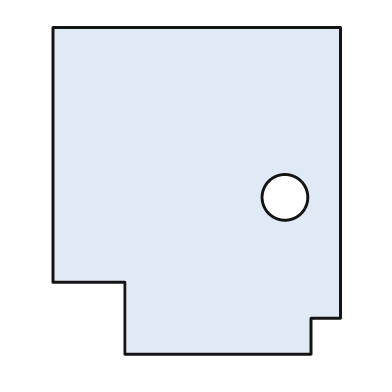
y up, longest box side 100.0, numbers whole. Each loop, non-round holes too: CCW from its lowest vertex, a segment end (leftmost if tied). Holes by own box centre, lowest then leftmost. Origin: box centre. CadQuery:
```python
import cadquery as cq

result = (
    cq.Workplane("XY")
    .moveTo(-22.0, -50.0)
    .lineTo(35.0, -50.0)
    .lineTo(35.0, -39.0)
    .lineTo(44.0, -39.0)
    .lineTo(44.0, 50.0)
    .lineTo(-44.0, 50.0)
    .lineTo(-44.0, -28.0)
    .lineTo(-22.0, -28.0)
    .close()
    .moveTo(27.0, -2.0)
    .circle(7.0)
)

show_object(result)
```